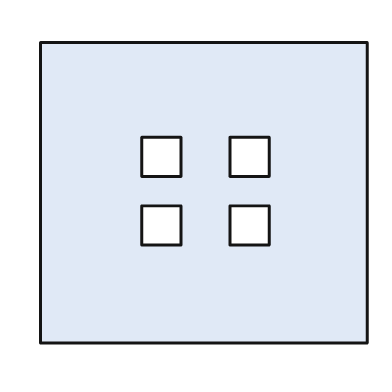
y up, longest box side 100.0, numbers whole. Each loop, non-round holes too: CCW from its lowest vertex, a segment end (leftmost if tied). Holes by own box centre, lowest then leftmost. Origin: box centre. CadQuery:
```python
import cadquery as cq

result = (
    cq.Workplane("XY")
    .moveTo(-50.0, -46.0)
    .lineTo(50.0, -46.0)
    .lineTo(50.0, 46.0)
    .lineTo(-50.0, 46.0)
    .close()
    .moveTo(-19.0, -16.0)
    .lineTo(-7.0, -16.0)
    .lineTo(-7.0, -4.0)
    .lineTo(-19.0, -4.0)
    .close()
    .moveTo(8.0, -16.0)
    .lineTo(20.0, -16.0)
    .lineTo(20.0, -4.0)
    .lineTo(8.0, -4.0)
    .close()
    .moveTo(-19.0, 5.0)
    .lineTo(-7.0, 5.0)
    .lineTo(-7.0, 17.0)
    .lineTo(-19.0, 17.0)
    .close()
    .moveTo(8.0, 5.0)
    .lineTo(20.0, 5.0)
    .lineTo(20.0, 17.0)
    .lineTo(8.0, 17.0)
    .close()
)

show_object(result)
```